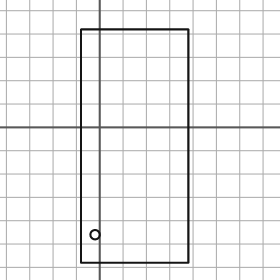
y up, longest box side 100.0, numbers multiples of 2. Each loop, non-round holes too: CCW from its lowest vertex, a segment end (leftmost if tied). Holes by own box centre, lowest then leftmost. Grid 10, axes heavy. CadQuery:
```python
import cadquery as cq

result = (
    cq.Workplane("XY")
    .moveTo(-8.0, -58.0)
    .lineTo(38.0, -58.0)
    .lineTo(38.0, 42.0)
    .lineTo(-8.0, 42.0)
    .close()
    .moveTo(-2.0, -46.0)
    .circle(2.0)
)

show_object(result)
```